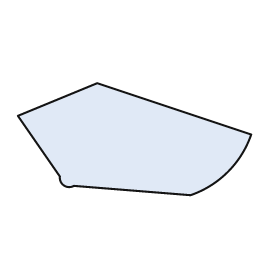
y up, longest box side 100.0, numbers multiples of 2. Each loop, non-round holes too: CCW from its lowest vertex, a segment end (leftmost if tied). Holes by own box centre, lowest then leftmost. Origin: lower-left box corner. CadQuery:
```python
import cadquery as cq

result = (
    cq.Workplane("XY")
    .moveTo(74.0, 0.0)
    .threePointArc((90.0, 10.0), (100.0, 26.0))
    .lineTo(34.0, 48.0)
    .lineTo(0.0, 34.0)
    .lineTo(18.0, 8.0)
    .threePointArc((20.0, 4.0), (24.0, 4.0))
    .close()
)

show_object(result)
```